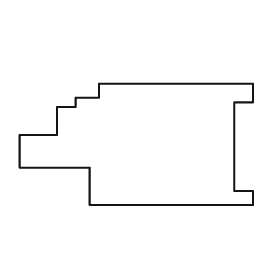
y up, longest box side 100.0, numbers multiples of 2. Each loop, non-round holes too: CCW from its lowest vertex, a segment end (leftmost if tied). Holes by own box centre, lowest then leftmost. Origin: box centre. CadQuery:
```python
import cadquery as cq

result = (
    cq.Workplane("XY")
    .moveTo(-20.0, -26.0)
    .lineTo(50.0, -26.0)
    .lineTo(50.0, -20.0)
    .lineTo(42.0, -20.0)
    .lineTo(42.0, 18.0)
    .lineTo(50.0, 18.0)
    .lineTo(50.0, 26.0)
    .lineTo(-16.0, 26.0)
    .lineTo(-16.0, 20.0)
    .lineTo(-26.0, 20.0)
    .lineTo(-26.0, 16.0)
    .lineTo(-34.0, 16.0)
    .lineTo(-34.0, 4.0)
    .lineTo(-50.0, 4.0)
    .lineTo(-50.0, -10.0)
    .lineTo(-20.0, -10.0)
    .close()
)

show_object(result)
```